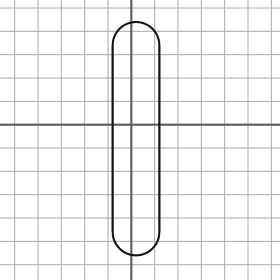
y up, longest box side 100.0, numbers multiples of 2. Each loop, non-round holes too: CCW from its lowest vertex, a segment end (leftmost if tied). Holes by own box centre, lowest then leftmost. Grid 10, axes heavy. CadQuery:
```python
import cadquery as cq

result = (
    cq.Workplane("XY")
    .moveTo(-8.0, -46.0)
    .threePointArc((2.0, -56.0), (12.0, -46.0))
    .lineTo(12.0, 34.0)
    .threePointArc((2.0, 44.0), (-8.0, 34.0))
    .close()
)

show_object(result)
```